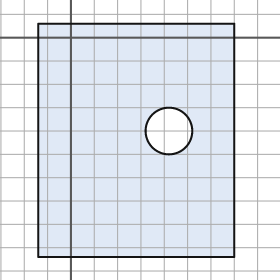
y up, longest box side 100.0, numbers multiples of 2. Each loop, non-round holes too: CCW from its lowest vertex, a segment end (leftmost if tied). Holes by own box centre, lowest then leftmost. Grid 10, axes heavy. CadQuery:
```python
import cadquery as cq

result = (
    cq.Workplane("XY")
    .moveTo(-14.0, -94.0)
    .lineTo(70.0, -94.0)
    .lineTo(70.0, 6.0)
    .lineTo(-14.0, 6.0)
    .close()
    .moveTo(42.0, -40.0)
    .circle(10.0)
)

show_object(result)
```